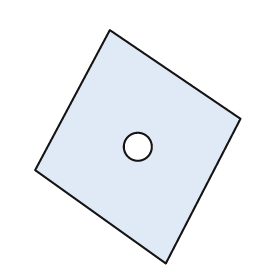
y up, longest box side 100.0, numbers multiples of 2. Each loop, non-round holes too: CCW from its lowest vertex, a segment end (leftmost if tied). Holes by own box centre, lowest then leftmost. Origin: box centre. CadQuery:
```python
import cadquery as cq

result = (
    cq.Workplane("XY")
    .moveTo(12.0, -50.0)
    .lineTo(44.0, 12.0)
    .lineTo(-12.0, 50.0)
    .lineTo(-44.0, -10.0)
    .close()
    .moveTo(0.0, 0.0)
    .circle(6.0)
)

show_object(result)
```